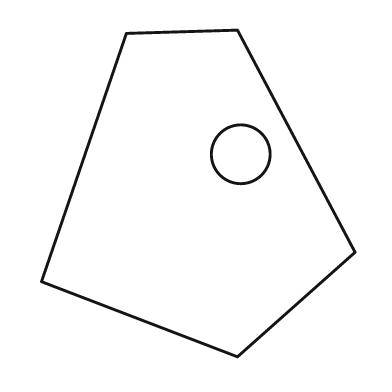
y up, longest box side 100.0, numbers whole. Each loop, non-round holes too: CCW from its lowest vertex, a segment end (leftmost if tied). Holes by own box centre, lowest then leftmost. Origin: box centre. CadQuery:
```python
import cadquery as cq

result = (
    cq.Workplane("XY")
    .moveTo(12.0, -50.0)
    .lineTo(48.0, -18.0)
    .lineTo(12.0, 50.0)
    .lineTo(-22.0, 49.0)
    .lineTo(-48.0, -27.0)
    .close()
    .moveTo(13.0, 12.0)
    .circle(9.0)
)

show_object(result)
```